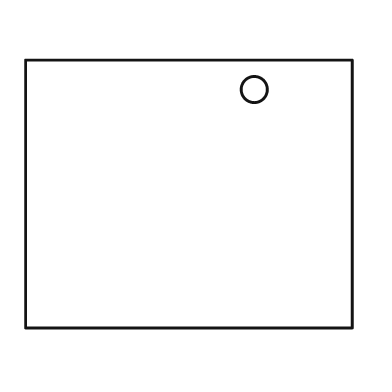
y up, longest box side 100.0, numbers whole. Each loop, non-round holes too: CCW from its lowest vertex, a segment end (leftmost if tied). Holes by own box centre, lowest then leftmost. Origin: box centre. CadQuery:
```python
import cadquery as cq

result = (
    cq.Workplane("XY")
    .moveTo(-50.0, -41.0)
    .lineTo(50.0, -41.0)
    .lineTo(50.0, 41.0)
    .lineTo(-50.0, 41.0)
    .close()
    .moveTo(20.0, 32.0)
    .circle(4.0)
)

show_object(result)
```